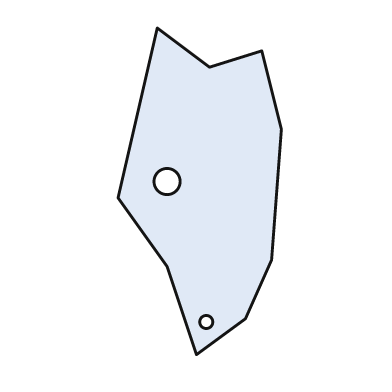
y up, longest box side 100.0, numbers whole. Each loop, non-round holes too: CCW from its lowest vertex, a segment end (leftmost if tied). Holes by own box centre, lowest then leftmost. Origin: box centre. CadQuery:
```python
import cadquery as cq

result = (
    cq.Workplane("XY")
    .moveTo(-1.0, -50.0)
    .lineTo(14.0, -39.0)
    .lineTo(22.0, -21.0)
    .lineTo(25.0, 19.0)
    .lineTo(19.0, 43.0)
    .lineTo(3.0, 38.0)
    .lineTo(-13.0, 50.0)
    .lineTo(-25.0, -2.0)
    .lineTo(-10.0, -23.0)
    .close()
    .moveTo(2.0, -40.0)
    .circle(2.0)
    .moveTo(-10.0, 3.0)
    .circle(4.0)
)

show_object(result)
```